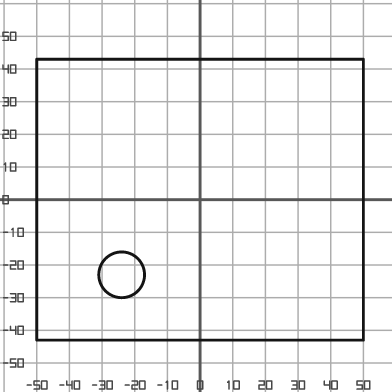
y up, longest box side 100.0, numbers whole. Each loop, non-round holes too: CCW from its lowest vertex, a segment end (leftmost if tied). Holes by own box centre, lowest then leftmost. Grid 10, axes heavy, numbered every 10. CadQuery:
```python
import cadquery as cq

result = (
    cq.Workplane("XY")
    .moveTo(-50.0, -43.0)
    .lineTo(50.0, -43.0)
    .lineTo(50.0, 43.0)
    .lineTo(-50.0, 43.0)
    .close()
    .moveTo(-24.0, -23.0)
    .circle(7.0)
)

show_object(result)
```